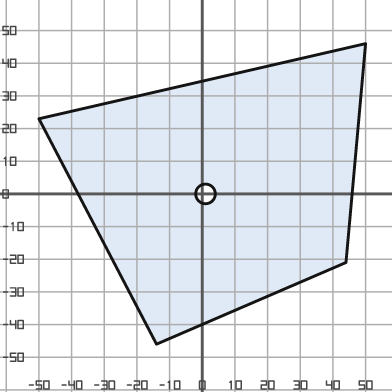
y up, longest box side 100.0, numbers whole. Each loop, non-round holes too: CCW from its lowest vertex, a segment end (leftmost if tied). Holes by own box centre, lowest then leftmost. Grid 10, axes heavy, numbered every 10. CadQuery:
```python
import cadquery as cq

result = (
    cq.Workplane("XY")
    .moveTo(-14.0, -46.0)
    .lineTo(44.0, -21.0)
    .lineTo(50.0, 46.0)
    .lineTo(-50.0, 23.0)
    .close()
    .moveTo(1.0, 0.0)
    .circle(3.0)
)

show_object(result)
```